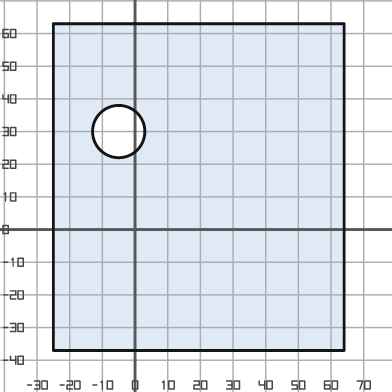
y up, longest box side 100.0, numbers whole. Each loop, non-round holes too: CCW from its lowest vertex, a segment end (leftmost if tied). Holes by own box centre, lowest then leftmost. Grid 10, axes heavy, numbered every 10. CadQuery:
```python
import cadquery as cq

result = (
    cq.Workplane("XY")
    .moveTo(-25.0, -37.0)
    .lineTo(64.0, -37.0)
    .lineTo(64.0, 63.0)
    .lineTo(-25.0, 63.0)
    .close()
    .moveTo(-5.0, 30.0)
    .circle(8.0)
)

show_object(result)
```